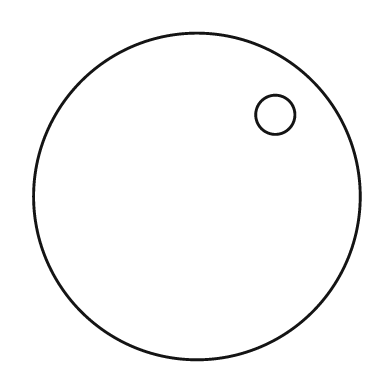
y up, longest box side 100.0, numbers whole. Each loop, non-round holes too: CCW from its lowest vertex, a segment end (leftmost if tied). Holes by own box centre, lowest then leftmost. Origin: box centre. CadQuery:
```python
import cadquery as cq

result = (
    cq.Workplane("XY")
    .moveTo(0.0, 0.0)
    .circle(50.0)
    .moveTo(24.0, 25.0)
    .circle(6.0)
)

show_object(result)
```